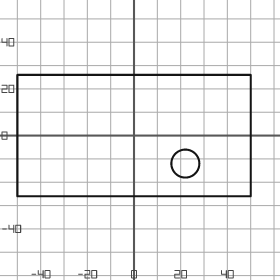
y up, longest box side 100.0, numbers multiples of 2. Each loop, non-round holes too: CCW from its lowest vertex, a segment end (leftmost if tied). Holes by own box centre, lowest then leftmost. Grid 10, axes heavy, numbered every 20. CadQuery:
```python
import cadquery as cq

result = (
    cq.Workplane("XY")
    .moveTo(-50.0, -26.0)
    .lineTo(50.0, -26.0)
    .lineTo(50.0, 26.0)
    .lineTo(-50.0, 26.0)
    .close()
    .moveTo(22.0, -12.0)
    .circle(6.0)
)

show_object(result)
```